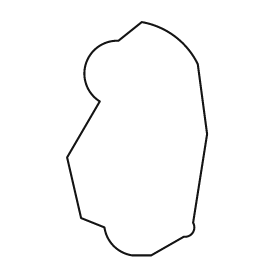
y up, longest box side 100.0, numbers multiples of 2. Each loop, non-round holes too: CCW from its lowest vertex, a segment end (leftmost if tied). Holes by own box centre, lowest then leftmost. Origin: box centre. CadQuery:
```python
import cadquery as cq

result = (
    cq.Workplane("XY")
    .moveTo(-2.0, -50.0)
    .lineTo(6.0, -50.0)
    .lineTo(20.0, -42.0)
    .threePointArc((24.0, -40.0), (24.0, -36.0))
    .lineTo(30.0, 2.0)
    .lineTo(26.0, 32.0)
    .threePointArc((16.0, 44.0), (2.0, 50.0))
    .lineTo(-8.0, 42.0)
    .threePointArc((-22.0, 32.0), (-16.0, 16.0))
    .lineTo(-30.0, -8.0)
    .lineTo(-24.0, -34.0)
    .lineTo(-14.0, -38.0)
    .threePointArc((-10.0, -46.0), (-2.0, -50.0))
    .close()
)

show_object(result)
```